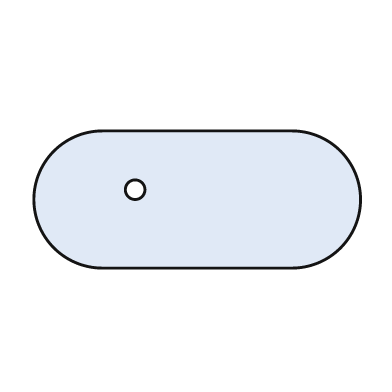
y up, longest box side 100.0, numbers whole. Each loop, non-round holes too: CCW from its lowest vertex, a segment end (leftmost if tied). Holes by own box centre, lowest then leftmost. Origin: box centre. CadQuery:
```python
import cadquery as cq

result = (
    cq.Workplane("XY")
    .moveTo(-29.0, -21.0)
    .lineTo(29.0, -21.0)
    .threePointArc((50.0, 0.0), (29.0, 21.0))
    .lineTo(-29.0, 21.0)
    .threePointArc((-50.0, 0.0), (-29.0, -21.0))
    .close()
    .moveTo(-19.0, 3.0)
    .circle(3.0)
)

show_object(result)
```